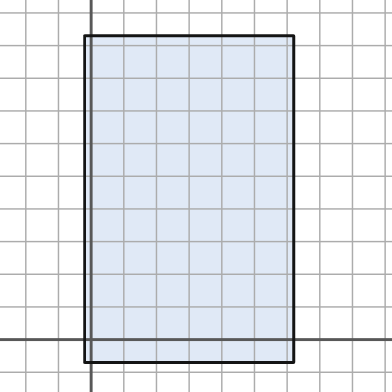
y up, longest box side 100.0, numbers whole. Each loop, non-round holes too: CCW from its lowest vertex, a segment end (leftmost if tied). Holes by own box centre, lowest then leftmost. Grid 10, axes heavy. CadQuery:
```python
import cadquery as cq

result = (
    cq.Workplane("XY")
    .moveTo(-2.0, -7.0)
    .lineTo(62.0, -7.0)
    .lineTo(62.0, 93.0)
    .lineTo(-2.0, 93.0)
    .close()
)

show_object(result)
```